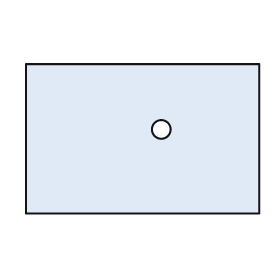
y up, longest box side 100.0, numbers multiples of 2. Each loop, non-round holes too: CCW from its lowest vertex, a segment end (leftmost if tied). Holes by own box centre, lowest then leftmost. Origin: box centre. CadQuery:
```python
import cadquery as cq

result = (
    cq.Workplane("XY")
    .moveTo(-50.0, -32.0)
    .lineTo(50.0, -32.0)
    .lineTo(50.0, 32.0)
    .lineTo(-50.0, 32.0)
    .close()
    .moveTo(8.0, 4.0)
    .circle(4.0)
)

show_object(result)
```